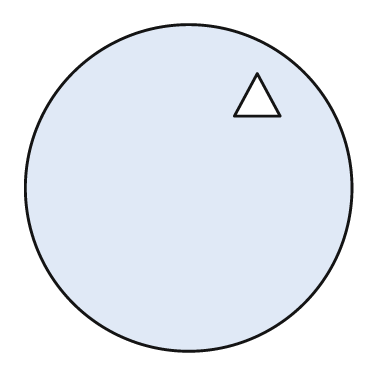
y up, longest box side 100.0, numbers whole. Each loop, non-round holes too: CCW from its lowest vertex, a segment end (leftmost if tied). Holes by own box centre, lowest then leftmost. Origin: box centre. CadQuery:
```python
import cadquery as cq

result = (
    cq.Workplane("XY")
    .moveTo(0.0, 0.0)
    .circle(50.0)
    .moveTo(14.0, 22.0)
    .lineTo(28.0, 22.0)
    .lineTo(21.0, 35.0)
    .close()
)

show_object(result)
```